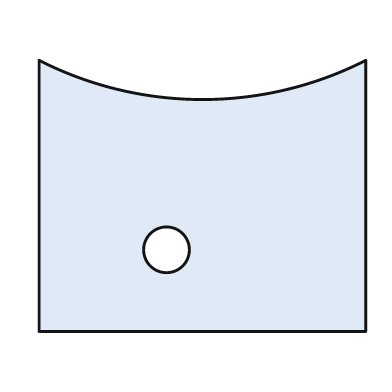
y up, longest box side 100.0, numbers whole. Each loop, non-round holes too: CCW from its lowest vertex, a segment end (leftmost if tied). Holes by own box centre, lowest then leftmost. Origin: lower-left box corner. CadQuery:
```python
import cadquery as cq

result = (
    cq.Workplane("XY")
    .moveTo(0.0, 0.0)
    .lineTo(100.0, 0.0)
    .lineTo(100.0, 83.0)
    .threePointArc((50.0, 71.0), (0.0, 83.0))
    .close()
    .moveTo(39.0, 25.0)
    .circle(7.0)
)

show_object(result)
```